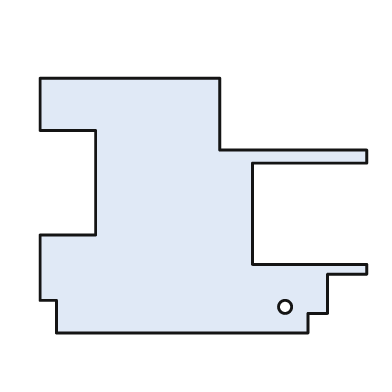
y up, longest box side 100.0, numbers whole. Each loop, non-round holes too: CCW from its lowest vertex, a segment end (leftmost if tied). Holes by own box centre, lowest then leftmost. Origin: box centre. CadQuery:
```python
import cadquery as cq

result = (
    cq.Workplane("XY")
    .moveTo(-45.0, -39.0)
    .lineTo(32.0, -39.0)
    .lineTo(32.0, -33.0)
    .lineTo(38.0, -33.0)
    .lineTo(38.0, -21.0)
    .lineTo(50.0, -21.0)
    .lineTo(50.0, -18.0)
    .lineTo(15.0, -18.0)
    .lineTo(15.0, 13.0)
    .lineTo(50.0, 13.0)
    .lineTo(50.0, 17.0)
    .lineTo(5.0, 17.0)
    .lineTo(5.0, 39.0)
    .lineTo(-50.0, 39.0)
    .lineTo(-50.0, 23.0)
    .lineTo(-33.0, 23.0)
    .lineTo(-33.0, -9.0)
    .lineTo(-50.0, -9.0)
    .lineTo(-50.0, -29.0)
    .lineTo(-45.0, -29.0)
    .close()
    .moveTo(25.0, -31.0)
    .circle(2.0)
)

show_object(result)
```